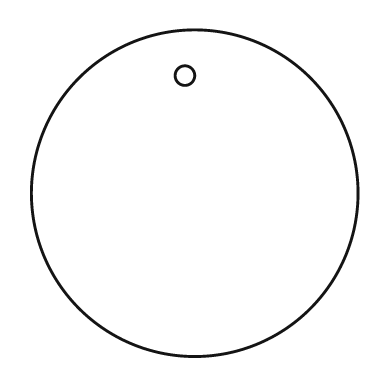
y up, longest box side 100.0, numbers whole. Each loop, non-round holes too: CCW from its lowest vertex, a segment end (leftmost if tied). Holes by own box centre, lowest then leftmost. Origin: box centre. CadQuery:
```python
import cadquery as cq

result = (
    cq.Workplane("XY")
    .moveTo(0.0, 0.0)
    .circle(50.0)
    .moveTo(-3.0, 36.0)
    .circle(3.0)
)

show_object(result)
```